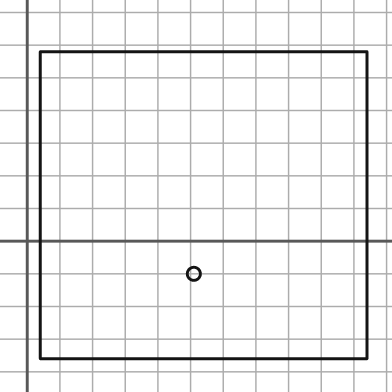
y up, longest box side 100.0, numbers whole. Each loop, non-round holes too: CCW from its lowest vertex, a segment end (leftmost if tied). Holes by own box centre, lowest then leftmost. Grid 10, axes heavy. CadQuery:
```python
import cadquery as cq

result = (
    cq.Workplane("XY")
    .moveTo(4.0, -36.0)
    .lineTo(104.0, -36.0)
    .lineTo(104.0, 58.0)
    .lineTo(4.0, 58.0)
    .close()
    .moveTo(51.0, -10.0)
    .circle(2.0)
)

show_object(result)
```